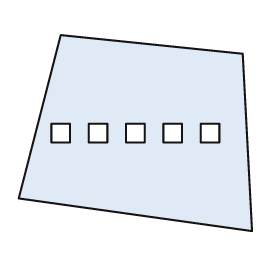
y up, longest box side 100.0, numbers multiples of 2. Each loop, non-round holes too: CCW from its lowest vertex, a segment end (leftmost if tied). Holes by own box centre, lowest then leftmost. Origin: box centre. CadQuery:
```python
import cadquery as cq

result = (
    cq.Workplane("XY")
    .moveTo(50.0, -42.0)
    .lineTo(46.0, 34.0)
    .lineTo(-32.0, 42.0)
    .lineTo(-50.0, -28.0)
    .close()
    .moveTo(-36.0, -4.0)
    .lineTo(-28.0, -4.0)
    .lineTo(-28.0, 4.0)
    .lineTo(-36.0, 4.0)
    .close()
    .moveTo(-20.0, -4.0)
    .lineTo(-12.0, -4.0)
    .lineTo(-12.0, 4.0)
    .lineTo(-20.0, 4.0)
    .close()
    .moveTo(-4.0, -4.0)
    .lineTo(4.0, -4.0)
    .lineTo(4.0, 4.0)
    .lineTo(-4.0, 4.0)
    .close()
    .moveTo(12.0, -4.0)
    .lineTo(20.0, -4.0)
    .lineTo(20.0, 4.0)
    .lineTo(12.0, 4.0)
    .close()
    .moveTo(28.0, -4.0)
    .lineTo(36.0, -4.0)
    .lineTo(36.0, 4.0)
    .lineTo(28.0, 4.0)
    .close()
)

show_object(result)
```